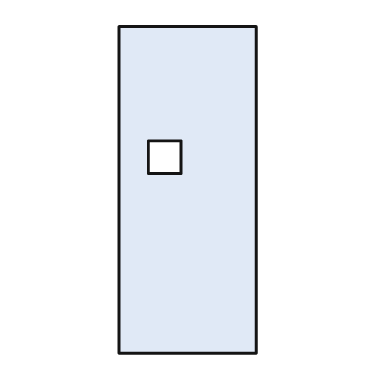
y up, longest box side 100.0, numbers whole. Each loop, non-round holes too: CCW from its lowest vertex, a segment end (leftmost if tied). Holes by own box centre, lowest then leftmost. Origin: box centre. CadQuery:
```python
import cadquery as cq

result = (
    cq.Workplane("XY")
    .moveTo(-21.0, -50.0)
    .lineTo(21.0, -50.0)
    .lineTo(21.0, 50.0)
    .lineTo(-21.0, 50.0)
    .close()
    .moveTo(-12.0, 5.0)
    .lineTo(-2.0, 5.0)
    .lineTo(-2.0, 15.0)
    .lineTo(-12.0, 15.0)
    .close()
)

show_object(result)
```